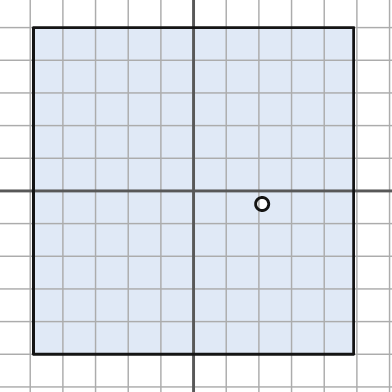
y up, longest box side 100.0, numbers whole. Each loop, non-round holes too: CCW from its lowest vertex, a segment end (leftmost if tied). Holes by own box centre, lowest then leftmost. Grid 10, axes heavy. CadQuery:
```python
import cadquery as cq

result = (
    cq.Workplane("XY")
    .moveTo(-49.0, -50.0)
    .lineTo(49.0, -50.0)
    .lineTo(49.0, 50.0)
    .lineTo(-49.0, 50.0)
    .close()
    .moveTo(21.0, -4.0)
    .circle(2.0)
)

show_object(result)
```